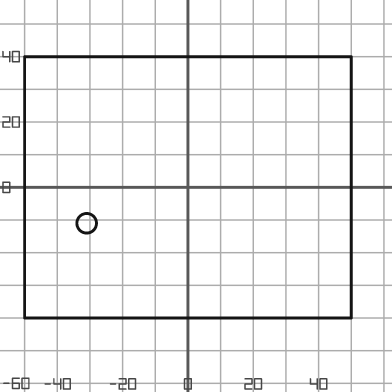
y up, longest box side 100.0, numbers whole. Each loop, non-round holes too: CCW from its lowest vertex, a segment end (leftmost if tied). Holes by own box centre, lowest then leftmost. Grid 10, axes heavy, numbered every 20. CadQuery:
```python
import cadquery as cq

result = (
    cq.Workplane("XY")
    .moveTo(-50.0, -40.0)
    .lineTo(50.0, -40.0)
    .lineTo(50.0, 40.0)
    .lineTo(-50.0, 40.0)
    .close()
    .moveTo(-31.0, -11.0)
    .circle(3.0)
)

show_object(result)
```